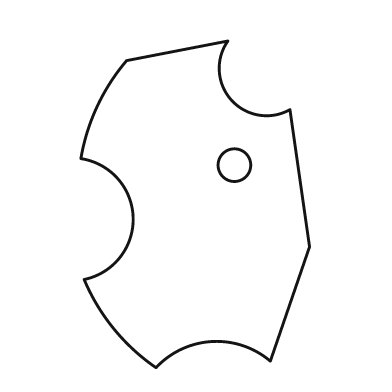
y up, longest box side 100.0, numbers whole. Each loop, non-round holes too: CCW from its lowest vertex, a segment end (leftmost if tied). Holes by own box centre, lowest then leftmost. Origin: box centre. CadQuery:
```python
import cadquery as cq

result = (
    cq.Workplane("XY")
    .moveTo(-12.0, -50.0)
    .threePointArc((5.0, -42.0), (23.0, -48.0))
    .lineTo(35.0, -13.0)
    .lineTo(29.0, 29.0)
    .threePointArc((11.0, 32.0), (10.0, 50.0))
    .lineTo(-21.0, 44.0)
    .threePointArc((-30.0, 30.0), (-35.0, 14.0))
    .threePointArc((-19.0, -4.0), (-34.0, -23.0))
    .threePointArc((-25.0, -38.0), (-12.0, -50.0))
    .close()
    .moveTo(12.0, 12.0)
    .circle(5.0)
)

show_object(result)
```